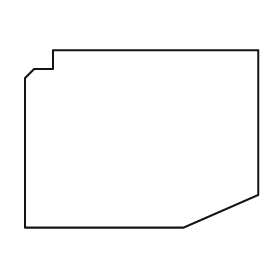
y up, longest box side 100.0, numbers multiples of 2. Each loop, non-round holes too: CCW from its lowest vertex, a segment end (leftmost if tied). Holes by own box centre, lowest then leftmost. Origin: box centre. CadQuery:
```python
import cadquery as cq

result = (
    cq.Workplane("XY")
    .moveTo(-50.0, -38.0)
    .lineTo(18.0, -38.0)
    .lineTo(50.0, -24.0)
    .lineTo(50.0, 38.0)
    .lineTo(-38.0, 38.0)
    .lineTo(-38.0, 30.0)
    .lineTo(-46.0, 30.0)
    .lineTo(-50.0, 26.0)
    .close()
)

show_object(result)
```